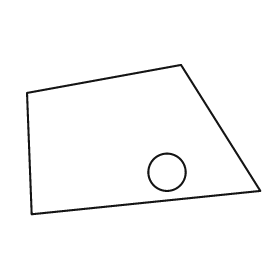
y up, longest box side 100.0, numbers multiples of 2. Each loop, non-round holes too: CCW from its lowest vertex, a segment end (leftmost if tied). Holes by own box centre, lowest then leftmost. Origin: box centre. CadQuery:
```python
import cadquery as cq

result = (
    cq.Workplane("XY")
    .moveTo(-48.0, -32.0)
    .lineTo(50.0, -22.0)
    .lineTo(16.0, 32.0)
    .lineTo(-50.0, 20.0)
    .close()
    .moveTo(10.0, -14.0)
    .circle(8.0)
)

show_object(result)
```